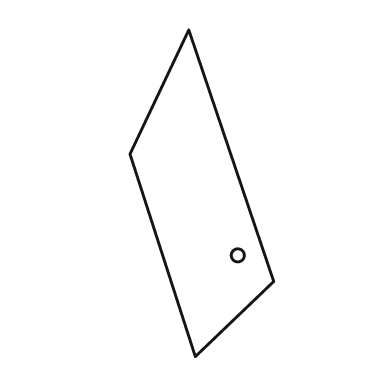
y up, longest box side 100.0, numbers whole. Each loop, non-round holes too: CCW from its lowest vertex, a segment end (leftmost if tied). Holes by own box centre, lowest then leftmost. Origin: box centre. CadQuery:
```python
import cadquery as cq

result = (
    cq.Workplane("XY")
    .moveTo(-2.0, -50.0)
    .lineTo(22.0, -27.0)
    .lineTo(-4.0, 50.0)
    .lineTo(-22.0, 12.0)
    .close()
    .moveTo(11.0, -19.0)
    .circle(2.0)
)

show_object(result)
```